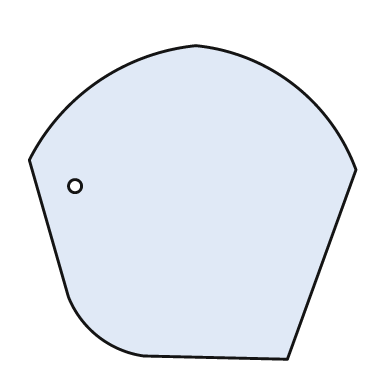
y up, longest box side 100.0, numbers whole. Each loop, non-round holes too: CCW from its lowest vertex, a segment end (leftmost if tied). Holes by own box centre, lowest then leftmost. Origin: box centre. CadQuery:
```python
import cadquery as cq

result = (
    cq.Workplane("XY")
    .moveTo(29.0, -48.0)
    .lineTo(50.0, 10.0)
    .threePointArc((31.0, 36.0), (1.0, 48.0))
    .threePointArc((-29.0, 37.0), (-50.0, 13.0))
    .lineTo(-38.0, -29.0)
    .threePointArc((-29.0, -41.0), (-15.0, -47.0))
    .close()
    .moveTo(-36.0, 5.0)
    .circle(2.0)
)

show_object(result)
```